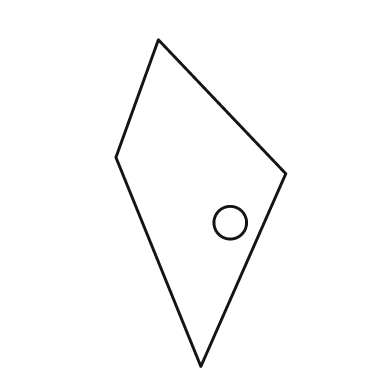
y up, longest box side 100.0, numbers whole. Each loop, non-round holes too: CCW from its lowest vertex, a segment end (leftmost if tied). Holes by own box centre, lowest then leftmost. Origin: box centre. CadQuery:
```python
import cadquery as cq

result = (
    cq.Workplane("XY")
    .moveTo(0.0, -50.0)
    .lineTo(26.0, 9.0)
    .lineTo(-13.0, 50.0)
    .lineTo(-26.0, 14.0)
    .close()
    .moveTo(9.0, -6.0)
    .circle(5.0)
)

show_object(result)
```